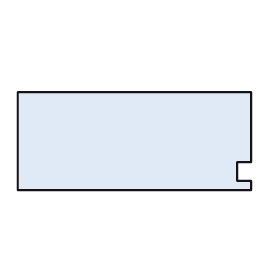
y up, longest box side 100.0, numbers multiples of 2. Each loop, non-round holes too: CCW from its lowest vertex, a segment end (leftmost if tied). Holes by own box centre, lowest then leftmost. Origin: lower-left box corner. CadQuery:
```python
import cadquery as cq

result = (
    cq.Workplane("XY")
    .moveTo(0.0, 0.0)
    .lineTo(100.0, 0.0)
    .lineTo(100.0, 4.0)
    .lineTo(94.0, 4.0)
    .lineTo(94.0, 12.0)
    .lineTo(100.0, 12.0)
    .lineTo(100.0, 42.0)
    .lineTo(0.0, 42.0)
    .close()
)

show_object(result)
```